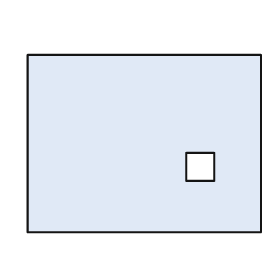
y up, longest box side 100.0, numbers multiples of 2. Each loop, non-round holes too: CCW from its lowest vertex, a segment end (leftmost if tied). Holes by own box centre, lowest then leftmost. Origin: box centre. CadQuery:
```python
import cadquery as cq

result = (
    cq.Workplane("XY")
    .moveTo(-50.0, -38.0)
    .lineTo(50.0, -38.0)
    .lineTo(50.0, 38.0)
    .lineTo(-50.0, 38.0)
    .close()
    .moveTo(18.0, -16.0)
    .lineTo(30.0, -16.0)
    .lineTo(30.0, -4.0)
    .lineTo(18.0, -4.0)
    .close()
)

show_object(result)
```